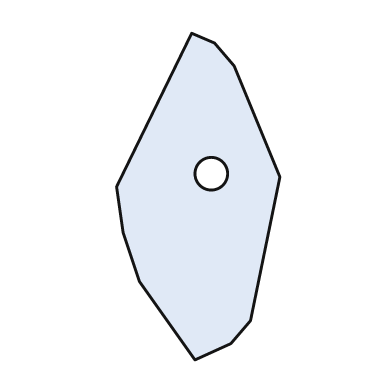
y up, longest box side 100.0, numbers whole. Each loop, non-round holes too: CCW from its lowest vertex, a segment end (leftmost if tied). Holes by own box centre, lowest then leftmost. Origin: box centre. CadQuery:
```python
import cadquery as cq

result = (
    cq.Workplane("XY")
    .moveTo(-1.0, -50.0)
    .lineTo(10.0, -45.0)
    .lineTo(16.0, -38.0)
    .lineTo(25.0, 6.0)
    .lineTo(11.0, 40.0)
    .lineTo(5.0, 47.0)
    .lineTo(-2.0, 50.0)
    .lineTo(-25.0, 3.0)
    .lineTo(-23.0, -11.0)
    .lineTo(-18.0, -26.0)
    .close()
    .moveTo(4.0, 7.0)
    .circle(5.0)
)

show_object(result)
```